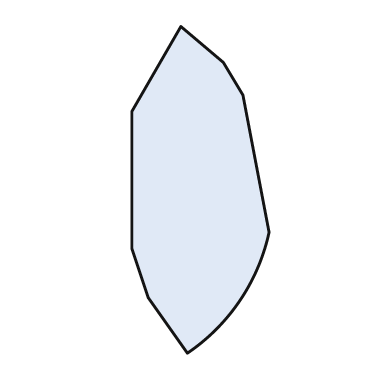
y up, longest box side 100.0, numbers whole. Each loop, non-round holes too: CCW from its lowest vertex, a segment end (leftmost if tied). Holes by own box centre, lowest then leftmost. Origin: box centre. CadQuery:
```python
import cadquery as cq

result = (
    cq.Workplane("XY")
    .moveTo(-4.0, -50.0)
    .threePointArc((12.0, -34.0), (21.0, -13.0))
    .lineTo(13.0, 29.0)
    .lineTo(7.0, 39.0)
    .lineTo(-6.0, 50.0)
    .lineTo(-21.0, 24.0)
    .lineTo(-21.0, -18.0)
    .lineTo(-16.0, -33.0)
    .close()
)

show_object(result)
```